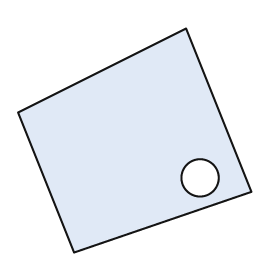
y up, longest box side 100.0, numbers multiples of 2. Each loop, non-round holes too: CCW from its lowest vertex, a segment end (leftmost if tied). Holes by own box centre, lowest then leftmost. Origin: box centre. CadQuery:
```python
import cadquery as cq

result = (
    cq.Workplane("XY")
    .moveTo(-26.0, -48.0)
    .lineTo(50.0, -22.0)
    .lineTo(22.0, 48.0)
    .lineTo(-50.0, 12.0)
    .close()
    .moveTo(28.0, -16.0)
    .circle(8.0)
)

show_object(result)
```